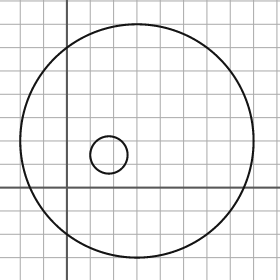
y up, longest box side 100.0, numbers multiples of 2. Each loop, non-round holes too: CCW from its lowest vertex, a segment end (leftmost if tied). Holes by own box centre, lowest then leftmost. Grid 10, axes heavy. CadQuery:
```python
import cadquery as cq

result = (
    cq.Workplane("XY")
    .moveTo(30.0, 20.0)
    .circle(50.0)
    .moveTo(18.0, 14.0)
    .circle(8.0)
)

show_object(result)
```